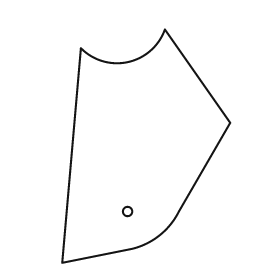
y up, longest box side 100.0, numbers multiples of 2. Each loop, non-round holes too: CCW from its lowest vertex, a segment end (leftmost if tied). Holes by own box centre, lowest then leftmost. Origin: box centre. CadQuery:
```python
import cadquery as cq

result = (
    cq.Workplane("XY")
    .moveTo(-36.0, -50.0)
    .lineTo(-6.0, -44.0)
    .threePointArc((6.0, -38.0), (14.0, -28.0))
    .lineTo(36.0, 10.0)
    .lineTo(8.0, 50.0)
    .threePointArc((-8.0, 36.0), (-28.0, 42.0))
    .close()
    .moveTo(-8.0, -28.0)
    .circle(2.0)
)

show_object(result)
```